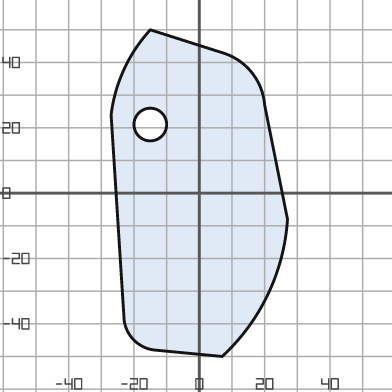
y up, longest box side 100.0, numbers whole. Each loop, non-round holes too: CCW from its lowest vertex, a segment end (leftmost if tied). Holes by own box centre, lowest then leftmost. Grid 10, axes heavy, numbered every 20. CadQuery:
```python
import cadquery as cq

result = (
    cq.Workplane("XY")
    .moveTo(7.0, -50.0)
    .threePointArc((21.0, -31.0), (27.0, -8.0))
    .lineTo(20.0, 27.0)
    .threePointArc((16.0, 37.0), (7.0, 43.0))
    .lineTo(-15.0, 50.0)
    .threePointArc((-23.0, 38.0), (-27.0, 24.0))
    .lineTo(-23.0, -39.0)
    .threePointArc((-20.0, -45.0), (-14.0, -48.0))
    .close()
    .moveTo(-15.0, 21.0)
    .circle(5.0)
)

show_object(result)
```